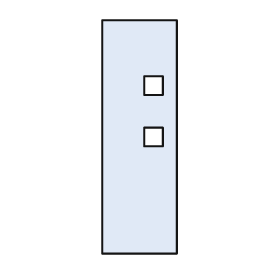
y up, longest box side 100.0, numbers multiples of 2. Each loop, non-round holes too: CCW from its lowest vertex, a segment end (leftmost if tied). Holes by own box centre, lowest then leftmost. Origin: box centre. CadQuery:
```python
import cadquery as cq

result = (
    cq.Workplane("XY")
    .moveTo(-16.0, -50.0)
    .lineTo(16.0, -50.0)
    .lineTo(16.0, 50.0)
    .lineTo(-16.0, 50.0)
    .close()
    .moveTo(2.0, -4.0)
    .lineTo(10.0, -4.0)
    .lineTo(10.0, 4.0)
    .lineTo(2.0, 4.0)
    .close()
    .moveTo(2.0, 18.0)
    .lineTo(10.0, 18.0)
    .lineTo(10.0, 26.0)
    .lineTo(2.0, 26.0)
    .close()
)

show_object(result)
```